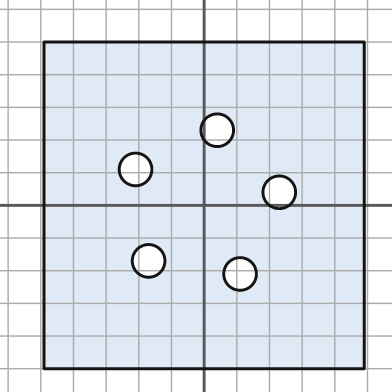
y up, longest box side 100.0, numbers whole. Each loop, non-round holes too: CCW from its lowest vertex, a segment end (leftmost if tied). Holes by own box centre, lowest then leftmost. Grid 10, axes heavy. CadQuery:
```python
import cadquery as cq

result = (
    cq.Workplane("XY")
    .moveTo(-49.0, -50.0)
    .lineTo(49.0, -50.0)
    .lineTo(49.0, 50.0)
    .lineTo(-49.0, 50.0)
    .close()
    .moveTo(11.0, -21.0)
    .circle(5.0)
    .moveTo(-17.0, -17.0)
    .circle(5.0)
    .moveTo(23.0, 4.0)
    .circle(5.0)
    .moveTo(-21.0, 11.0)
    .circle(5.0)
    .moveTo(4.0, 23.0)
    .circle(5.0)
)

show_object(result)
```